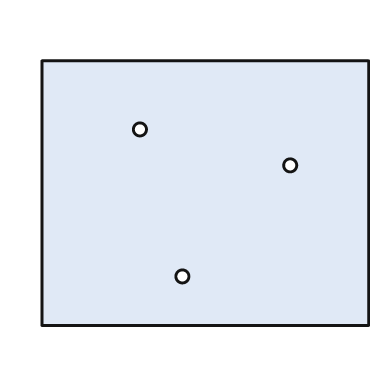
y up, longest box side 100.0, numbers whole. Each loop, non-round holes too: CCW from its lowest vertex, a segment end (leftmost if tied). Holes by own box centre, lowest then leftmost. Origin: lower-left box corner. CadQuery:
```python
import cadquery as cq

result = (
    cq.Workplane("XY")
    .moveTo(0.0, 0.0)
    .lineTo(100.0, 0.0)
    .lineTo(100.0, 81.0)
    .lineTo(0.0, 81.0)
    .close()
    .moveTo(43.0, 15.0)
    .circle(2.0)
    .moveTo(76.0, 49.0)
    .circle(2.0)
    .moveTo(30.0, 60.0)
    .circle(2.0)
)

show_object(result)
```